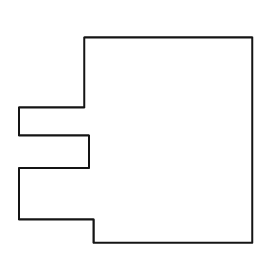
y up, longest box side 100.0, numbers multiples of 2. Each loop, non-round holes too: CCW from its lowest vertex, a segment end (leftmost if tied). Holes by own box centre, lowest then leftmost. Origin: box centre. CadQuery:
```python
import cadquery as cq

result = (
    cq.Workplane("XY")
    .moveTo(-18.0, -44.0)
    .lineTo(50.0, -44.0)
    .lineTo(50.0, 44.0)
    .lineTo(-22.0, 44.0)
    .lineTo(-22.0, 14.0)
    .lineTo(-50.0, 14.0)
    .lineTo(-50.0, 2.0)
    .lineTo(-20.0, 2.0)
    .lineTo(-20.0, -12.0)
    .lineTo(-50.0, -12.0)
    .lineTo(-50.0, -34.0)
    .lineTo(-18.0, -34.0)
    .close()
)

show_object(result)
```